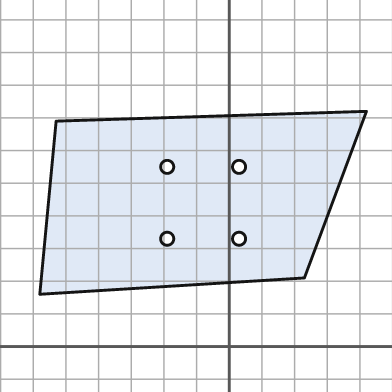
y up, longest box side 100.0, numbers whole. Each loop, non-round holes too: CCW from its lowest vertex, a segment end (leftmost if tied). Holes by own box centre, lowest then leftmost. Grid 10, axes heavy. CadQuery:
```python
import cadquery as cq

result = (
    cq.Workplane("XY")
    .moveTo(-58.0, 16.0)
    .lineTo(23.0, 21.0)
    .lineTo(42.0, 72.0)
    .lineTo(-53.0, 69.0)
    .close()
    .moveTo(-19.0, 33.0)
    .circle(2.0)
    .moveTo(3.0, 33.0)
    .circle(2.0)
    .moveTo(-19.0, 55.0)
    .circle(2.0)
    .moveTo(3.0, 55.0)
    .circle(2.0)
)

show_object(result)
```